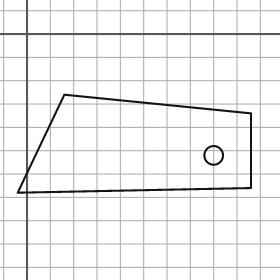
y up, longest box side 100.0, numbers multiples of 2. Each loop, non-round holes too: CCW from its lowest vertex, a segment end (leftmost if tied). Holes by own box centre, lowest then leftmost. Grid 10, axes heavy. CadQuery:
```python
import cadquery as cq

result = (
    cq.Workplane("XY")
    .moveTo(-4.0, -68.0)
    .lineTo(96.0, -66.0)
    .lineTo(96.0, -34.0)
    .lineTo(16.0, -26.0)
    .close()
    .moveTo(80.0, -52.0)
    .circle(4.0)
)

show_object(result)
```